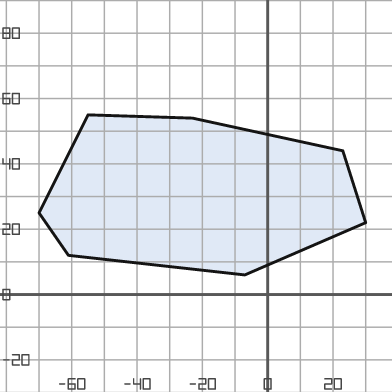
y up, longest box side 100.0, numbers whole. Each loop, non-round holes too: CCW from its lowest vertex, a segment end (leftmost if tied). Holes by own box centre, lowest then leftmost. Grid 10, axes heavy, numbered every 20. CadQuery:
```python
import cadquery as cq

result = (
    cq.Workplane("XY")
    .moveTo(-7.0, 6.0)
    .lineTo(30.0, 22.0)
    .lineTo(23.0, 44.0)
    .lineTo(-23.0, 54.0)
    .lineTo(-55.0, 55.0)
    .lineTo(-70.0, 25.0)
    .lineTo(-61.0, 12.0)
    .close()
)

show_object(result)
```